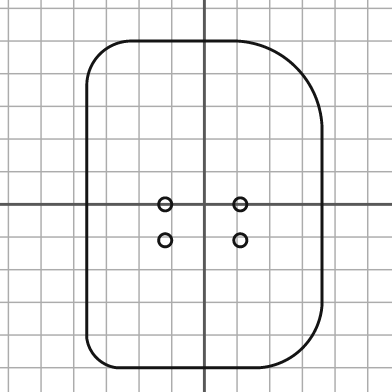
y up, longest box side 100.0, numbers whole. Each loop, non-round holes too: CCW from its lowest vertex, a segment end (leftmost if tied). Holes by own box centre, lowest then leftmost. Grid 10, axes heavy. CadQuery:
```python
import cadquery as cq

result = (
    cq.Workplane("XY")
    .moveTo(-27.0, -50.0)
    .lineTo(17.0, -50.0)
    .threePointArc((30.0, -44.0), (36.0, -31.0))
    .lineTo(36.0, 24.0)
    .threePointArc((28.0, 42.0), (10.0, 50.0))
    .lineTo(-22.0, 50.0)
    .threePointArc((-32.0, 46.0), (-36.0, 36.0))
    .lineTo(-36.0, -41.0)
    .threePointArc((-33.0, -47.0), (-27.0, -50.0))
    .close()
    .moveTo(-12.0, -11.0)
    .circle(2.0)
    .moveTo(11.0, -11.0)
    .circle(2.0)
    .moveTo(-12.0, 0.0)
    .circle(2.0)
    .moveTo(11.0, 0.0)
    .circle(2.0)
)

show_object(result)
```